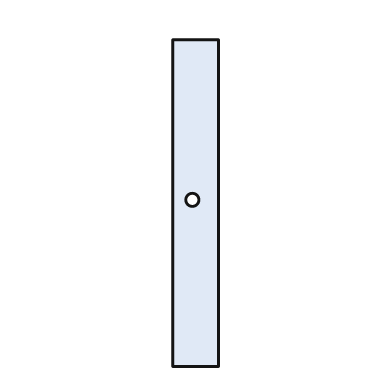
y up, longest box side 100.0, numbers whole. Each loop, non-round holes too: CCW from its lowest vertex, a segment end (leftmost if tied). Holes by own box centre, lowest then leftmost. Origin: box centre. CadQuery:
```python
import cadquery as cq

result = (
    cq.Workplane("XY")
    .moveTo(-7.0, -50.0)
    .lineTo(7.0, -50.0)
    .lineTo(7.0, 50.0)
    .lineTo(-7.0, 50.0)
    .close()
    .moveTo(-1.0, 1.0)
    .circle(2.0)
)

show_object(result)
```